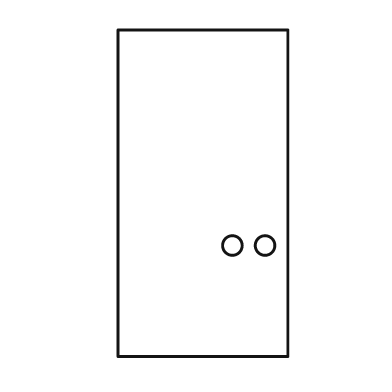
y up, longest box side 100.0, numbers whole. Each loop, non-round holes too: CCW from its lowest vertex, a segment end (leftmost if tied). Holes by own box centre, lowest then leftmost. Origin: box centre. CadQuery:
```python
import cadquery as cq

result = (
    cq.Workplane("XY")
    .moveTo(-26.0, -50.0)
    .lineTo(26.0, -50.0)
    .lineTo(26.0, 50.0)
    .lineTo(-26.0, 50.0)
    .close()
    .moveTo(9.0, -16.0)
    .circle(3.0)
    .moveTo(19.0, -16.0)
    .circle(3.0)
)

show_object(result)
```